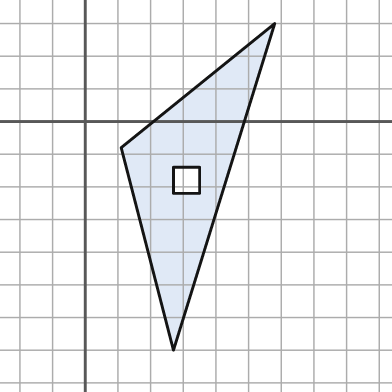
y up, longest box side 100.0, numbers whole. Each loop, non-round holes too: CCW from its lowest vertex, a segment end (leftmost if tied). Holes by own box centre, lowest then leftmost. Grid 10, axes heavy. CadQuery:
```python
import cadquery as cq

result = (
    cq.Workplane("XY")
    .moveTo(27.0, -70.0)
    .lineTo(58.0, 30.0)
    .lineTo(11.0, -8.0)
    .close()
    .moveTo(27.0, -22.0)
    .lineTo(35.0, -22.0)
    .lineTo(35.0, -14.0)
    .lineTo(27.0, -14.0)
    .close()
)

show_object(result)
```